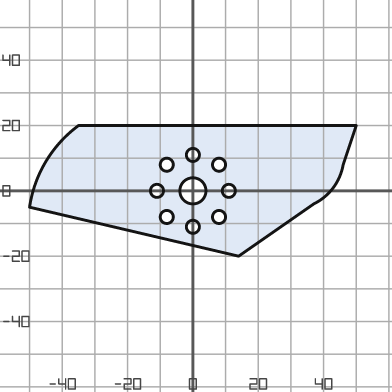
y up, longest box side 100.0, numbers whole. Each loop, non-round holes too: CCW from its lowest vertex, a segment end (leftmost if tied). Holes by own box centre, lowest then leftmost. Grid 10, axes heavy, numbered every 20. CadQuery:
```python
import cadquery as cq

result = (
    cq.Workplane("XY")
    .moveTo(14.0, -20.0)
    .lineTo(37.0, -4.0)
    .threePointArc((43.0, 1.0), (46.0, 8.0))
    .lineTo(50.0, 20.0)
    .lineTo(-35.0, 20.0)
    .threePointArc((-45.0, 9.0), (-50.0, -5.0))
    .close()
    .moveTo(0.0, -11.0)
    .circle(2.0)
    .moveTo(-8.0, -8.0)
    .circle(2.0)
    .moveTo(8.0, -8.0)
    .circle(2.0)
    .moveTo(-11.0, 0.0)
    .circle(2.0)
    .moveTo(0.0, 0.0)
    .circle(4.0)
    .moveTo(11.0, 0.0)
    .circle(2.0)
    .moveTo(-8.0, 8.0)
    .circle(2.0)
    .moveTo(8.0, 8.0)
    .circle(2.0)
    .moveTo(0.0, 11.0)
    .circle(2.0)
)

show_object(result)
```